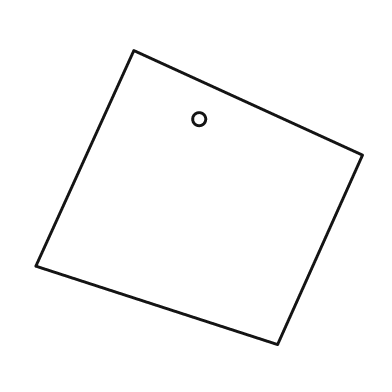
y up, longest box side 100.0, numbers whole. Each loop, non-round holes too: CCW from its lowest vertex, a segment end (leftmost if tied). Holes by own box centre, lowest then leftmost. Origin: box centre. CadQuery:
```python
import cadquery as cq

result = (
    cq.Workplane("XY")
    .moveTo(24.0, -45.0)
    .lineTo(50.0, 13.0)
    .lineTo(-20.0, 45.0)
    .lineTo(-50.0, -21.0)
    .close()
    .moveTo(0.0, 24.0)
    .circle(2.0)
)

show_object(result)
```